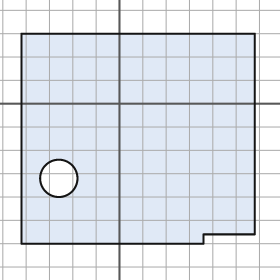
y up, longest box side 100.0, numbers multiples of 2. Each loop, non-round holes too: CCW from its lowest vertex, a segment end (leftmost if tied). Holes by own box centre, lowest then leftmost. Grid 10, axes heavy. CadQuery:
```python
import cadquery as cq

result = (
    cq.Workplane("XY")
    .moveTo(-42.0, -60.0)
    .lineTo(36.0, -60.0)
    .lineTo(36.0, -56.0)
    .lineTo(58.0, -56.0)
    .lineTo(58.0, 30.0)
    .lineTo(-42.0, 30.0)
    .close()
    .moveTo(-26.0, -32.0)
    .circle(8.0)
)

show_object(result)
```